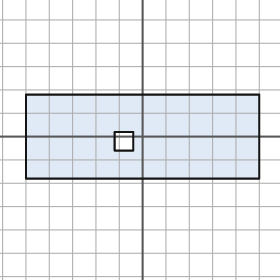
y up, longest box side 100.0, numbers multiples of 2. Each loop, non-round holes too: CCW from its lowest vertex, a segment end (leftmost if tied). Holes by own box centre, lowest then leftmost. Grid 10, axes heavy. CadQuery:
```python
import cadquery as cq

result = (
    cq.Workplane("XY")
    .moveTo(-50.0, -18.0)
    .lineTo(50.0, -18.0)
    .lineTo(50.0, 18.0)
    .lineTo(-50.0, 18.0)
    .close()
    .moveTo(-12.0, -6.0)
    .lineTo(-4.0, -6.0)
    .lineTo(-4.0, 2.0)
    .lineTo(-12.0, 2.0)
    .close()
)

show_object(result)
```